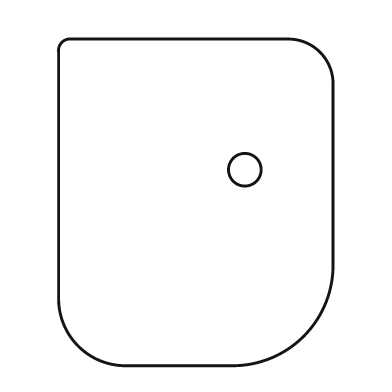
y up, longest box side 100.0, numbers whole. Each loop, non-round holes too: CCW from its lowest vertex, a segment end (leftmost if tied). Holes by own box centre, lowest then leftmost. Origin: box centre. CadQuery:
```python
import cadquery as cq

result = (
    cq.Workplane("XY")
    .moveTo(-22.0, -50.0)
    .lineTo(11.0, -50.0)
    .threePointArc((33.0, -41.0), (42.0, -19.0))
    .lineTo(42.0, 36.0)
    .threePointArc((38.0, 46.0), (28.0, 50.0))
    .lineTo(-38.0, 50.0)
    .threePointArc((-41.0, 49.0), (-42.0, 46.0))
    .lineTo(-42.0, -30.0)
    .threePointArc((-36.0, -44.0), (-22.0, -50.0))
    .close()
    .moveTo(15.0, 10.0)
    .circle(5.0)
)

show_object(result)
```